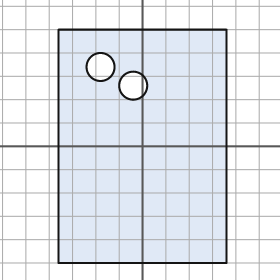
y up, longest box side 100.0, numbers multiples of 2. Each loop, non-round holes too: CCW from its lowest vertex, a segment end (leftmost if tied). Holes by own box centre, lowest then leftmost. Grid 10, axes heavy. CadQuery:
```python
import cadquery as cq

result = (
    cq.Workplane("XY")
    .moveTo(-36.0, -50.0)
    .lineTo(36.0, -50.0)
    .lineTo(36.0, 50.0)
    .lineTo(-36.0, 50.0)
    .close()
    .moveTo(-4.0, 26.0)
    .circle(6.0)
    .moveTo(-18.0, 34.0)
    .circle(6.0)
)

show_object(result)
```